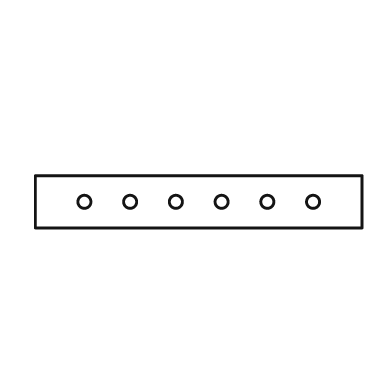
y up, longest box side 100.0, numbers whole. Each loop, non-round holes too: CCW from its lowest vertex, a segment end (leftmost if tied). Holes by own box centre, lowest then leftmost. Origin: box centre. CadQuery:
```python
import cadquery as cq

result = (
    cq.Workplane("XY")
    .moveTo(-50.0, -8.0)
    .lineTo(50.0, -8.0)
    .lineTo(50.0, 8.0)
    .lineTo(-50.0, 8.0)
    .close()
    .moveTo(-35.0, 0.0)
    .circle(2.0)
    .moveTo(-21.0, 0.0)
    .circle(2.0)
    .moveTo(-7.0, 0.0)
    .circle(2.0)
    .moveTo(7.0, 0.0)
    .circle(2.0)
    .moveTo(21.0, 0.0)
    .circle(2.0)
    .moveTo(35.0, 0.0)
    .circle(2.0)
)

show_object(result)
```